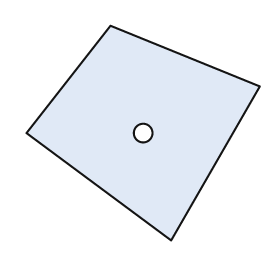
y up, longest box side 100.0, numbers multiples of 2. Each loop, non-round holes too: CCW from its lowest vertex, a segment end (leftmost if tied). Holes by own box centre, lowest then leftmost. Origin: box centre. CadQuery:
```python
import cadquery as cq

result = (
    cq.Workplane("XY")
    .moveTo(12.0, -46.0)
    .lineTo(50.0, 20.0)
    .lineTo(-14.0, 46.0)
    .lineTo(-50.0, 0.0)
    .close()
    .moveTo(0.0, 0.0)
    .circle(4.0)
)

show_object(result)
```